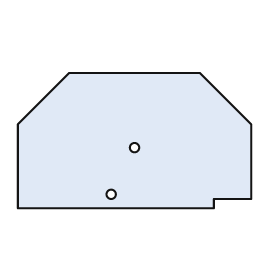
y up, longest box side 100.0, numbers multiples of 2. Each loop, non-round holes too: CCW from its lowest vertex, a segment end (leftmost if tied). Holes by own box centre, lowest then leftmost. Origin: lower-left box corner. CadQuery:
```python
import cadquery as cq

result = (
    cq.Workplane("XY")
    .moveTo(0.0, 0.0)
    .lineTo(84.0, 0.0)
    .lineTo(84.0, 4.0)
    .lineTo(100.0, 4.0)
    .lineTo(100.0, 36.0)
    .lineTo(78.0, 58.0)
    .lineTo(22.0, 58.0)
    .lineTo(0.0, 36.0)
    .close()
    .moveTo(40.0, 6.0)
    .circle(2.0)
    .moveTo(50.0, 26.0)
    .circle(2.0)
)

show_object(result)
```